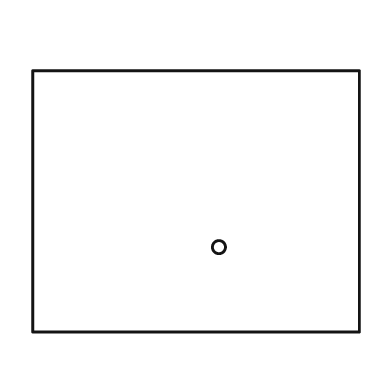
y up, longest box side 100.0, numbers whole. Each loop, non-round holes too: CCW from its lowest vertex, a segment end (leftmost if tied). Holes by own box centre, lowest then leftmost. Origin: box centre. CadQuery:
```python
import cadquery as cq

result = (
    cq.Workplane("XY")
    .moveTo(-50.0, -40.0)
    .lineTo(50.0, -40.0)
    .lineTo(50.0, 40.0)
    .lineTo(-50.0, 40.0)
    .close()
    .moveTo(7.0, -14.0)
    .circle(2.0)
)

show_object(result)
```